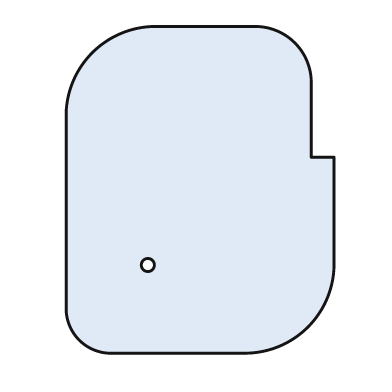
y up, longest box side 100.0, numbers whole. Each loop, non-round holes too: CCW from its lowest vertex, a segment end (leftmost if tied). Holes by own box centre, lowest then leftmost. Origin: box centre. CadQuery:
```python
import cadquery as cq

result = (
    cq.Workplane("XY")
    .moveTo(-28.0, -50.0)
    .lineTo(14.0, -50.0)
    .threePointArc((33.0, -42.0), (41.0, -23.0))
    .lineTo(41.0, 10.0)
    .lineTo(34.0, 10.0)
    .lineTo(34.0, 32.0)
    .threePointArc((29.0, 45.0), (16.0, 50.0))
    .lineTo(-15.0, 50.0)
    .threePointArc((-33.0, 42.0), (-41.0, 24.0))
    .lineTo(-41.0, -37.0)
    .threePointArc((-37.0, -46.0), (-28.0, -50.0))
    .close()
    .moveTo(-16.0, -23.0)
    .circle(2.0)
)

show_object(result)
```